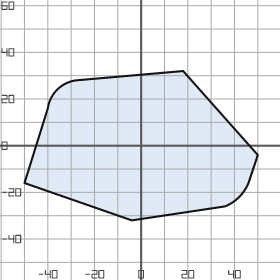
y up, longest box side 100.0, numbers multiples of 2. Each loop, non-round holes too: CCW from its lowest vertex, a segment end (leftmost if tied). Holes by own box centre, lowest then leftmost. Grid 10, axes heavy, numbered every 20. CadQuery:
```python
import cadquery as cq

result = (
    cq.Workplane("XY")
    .moveTo(-4.0, -32.0)
    .lineTo(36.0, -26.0)
    .threePointArc((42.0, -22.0), (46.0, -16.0))
    .lineTo(50.0, -4.0)
    .lineTo(18.0, 32.0)
    .lineTo(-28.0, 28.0)
    .threePointArc((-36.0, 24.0), (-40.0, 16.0))
    .lineTo(-50.0, -16.0)
    .close()
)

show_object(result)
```